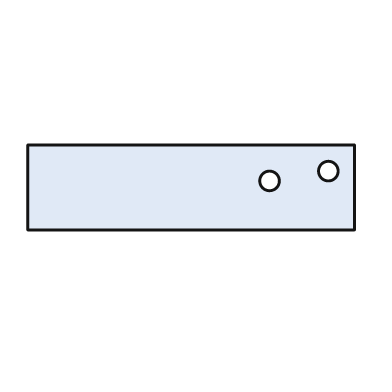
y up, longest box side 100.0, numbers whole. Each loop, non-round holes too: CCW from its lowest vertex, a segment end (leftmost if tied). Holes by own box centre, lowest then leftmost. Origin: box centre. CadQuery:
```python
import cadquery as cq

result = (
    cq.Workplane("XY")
    .moveTo(-50.0, -13.0)
    .lineTo(50.0, -13.0)
    .lineTo(50.0, 13.0)
    .lineTo(-50.0, 13.0)
    .close()
    .moveTo(24.0, 2.0)
    .circle(3.0)
    .moveTo(42.0, 5.0)
    .circle(3.0)
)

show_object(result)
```